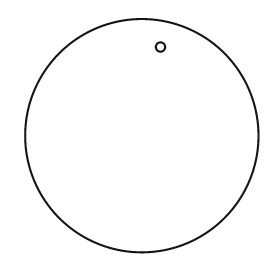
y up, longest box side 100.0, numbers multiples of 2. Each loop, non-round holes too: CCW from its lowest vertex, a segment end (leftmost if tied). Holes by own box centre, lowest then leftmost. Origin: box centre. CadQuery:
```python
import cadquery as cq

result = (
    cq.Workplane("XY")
    .moveTo(0.0, 0.0)
    .circle(50.0)
    .moveTo(8.0, 38.0)
    .circle(2.0)
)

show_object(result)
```